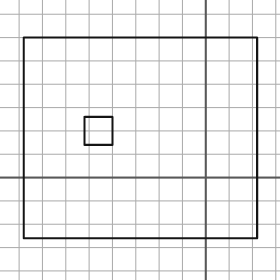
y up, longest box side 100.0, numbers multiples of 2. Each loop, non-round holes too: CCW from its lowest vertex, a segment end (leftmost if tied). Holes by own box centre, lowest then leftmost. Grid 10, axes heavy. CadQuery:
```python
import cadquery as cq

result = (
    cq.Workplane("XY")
    .moveTo(-78.0, -26.0)
    .lineTo(22.0, -26.0)
    .lineTo(22.0, 60.0)
    .lineTo(-78.0, 60.0)
    .close()
    .moveTo(-52.0, 14.0)
    .lineTo(-40.0, 14.0)
    .lineTo(-40.0, 26.0)
    .lineTo(-52.0, 26.0)
    .close()
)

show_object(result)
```